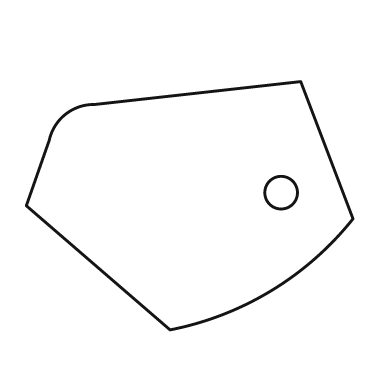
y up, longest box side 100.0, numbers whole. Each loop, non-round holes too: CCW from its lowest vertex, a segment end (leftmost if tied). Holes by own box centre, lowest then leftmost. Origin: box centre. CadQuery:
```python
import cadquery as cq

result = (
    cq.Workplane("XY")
    .moveTo(-6.0, -38.0)
    .threePointArc((25.0, -26.0), (50.0, -4.0))
    .lineTo(34.0, 38.0)
    .lineTo(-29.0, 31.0)
    .threePointArc((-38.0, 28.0), (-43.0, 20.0))
    .lineTo(-50.0, 0.0)
    .close()
    .moveTo(28.0, 4.0)
    .circle(5.0)
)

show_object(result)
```